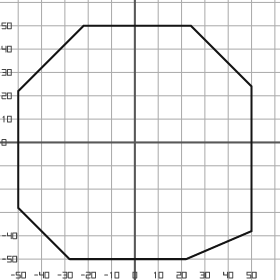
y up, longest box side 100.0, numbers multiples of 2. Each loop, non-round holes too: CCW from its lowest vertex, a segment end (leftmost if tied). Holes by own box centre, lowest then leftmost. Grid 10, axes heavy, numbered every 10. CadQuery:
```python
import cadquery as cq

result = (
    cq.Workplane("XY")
    .moveTo(-28.0, -50.0)
    .lineTo(22.0, -50.0)
    .lineTo(50.0, -38.0)
    .lineTo(50.0, 24.0)
    .lineTo(24.0, 50.0)
    .lineTo(-22.0, 50.0)
    .lineTo(-50.0, 22.0)
    .lineTo(-50.0, -28.0)
    .close()
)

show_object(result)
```